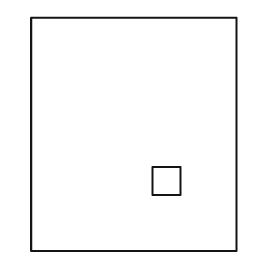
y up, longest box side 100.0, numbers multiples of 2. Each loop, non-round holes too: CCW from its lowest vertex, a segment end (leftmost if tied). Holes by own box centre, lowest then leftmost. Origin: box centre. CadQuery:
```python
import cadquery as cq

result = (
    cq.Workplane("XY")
    .moveTo(-44.0, -50.0)
    .lineTo(44.0, -50.0)
    .lineTo(44.0, 50.0)
    .lineTo(-44.0, 50.0)
    .close()
    .moveTo(8.0, -26.0)
    .lineTo(20.0, -26.0)
    .lineTo(20.0, -14.0)
    .lineTo(8.0, -14.0)
    .close()
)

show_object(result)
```